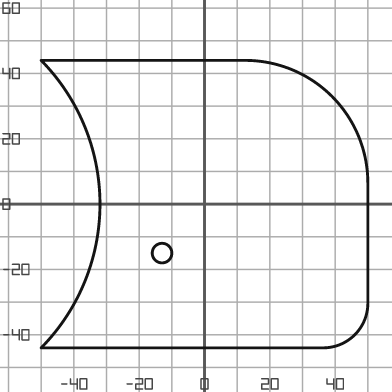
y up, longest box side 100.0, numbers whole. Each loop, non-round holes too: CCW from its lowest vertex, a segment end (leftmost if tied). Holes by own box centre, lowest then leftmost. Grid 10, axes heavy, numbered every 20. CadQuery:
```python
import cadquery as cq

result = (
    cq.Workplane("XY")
    .moveTo(-50.0, -44.0)
    .lineTo(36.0, -44.0)
    .threePointArc((46.0, -40.0), (50.0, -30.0))
    .lineTo(50.0, 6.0)
    .threePointArc((39.0, 33.0), (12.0, 44.0))
    .lineTo(-50.0, 44.0)
    .threePointArc((-32.0, 0.0), (-50.0, -44.0))
    .close()
    .moveTo(-13.0, -15.0)
    .circle(3.0)
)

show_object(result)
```